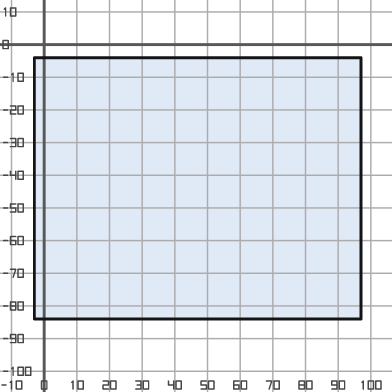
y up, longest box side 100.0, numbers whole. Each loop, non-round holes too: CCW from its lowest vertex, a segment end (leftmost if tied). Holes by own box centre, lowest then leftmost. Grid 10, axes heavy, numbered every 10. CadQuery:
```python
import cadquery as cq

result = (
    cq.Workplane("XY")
    .moveTo(-3.0, -84.0)
    .lineTo(97.0, -84.0)
    .lineTo(97.0, -4.0)
    .lineTo(-3.0, -4.0)
    .close()
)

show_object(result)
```